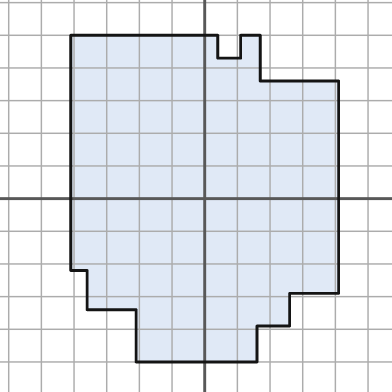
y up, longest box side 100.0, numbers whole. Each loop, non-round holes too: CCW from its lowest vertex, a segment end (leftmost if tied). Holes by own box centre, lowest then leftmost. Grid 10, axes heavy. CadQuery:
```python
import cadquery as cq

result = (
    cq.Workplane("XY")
    .moveTo(-21.0, -50.0)
    .lineTo(16.0, -50.0)
    .lineTo(16.0, -39.0)
    .lineTo(26.0, -39.0)
    .lineTo(26.0, -29.0)
    .lineTo(41.0, -29.0)
    .lineTo(41.0, 36.0)
    .lineTo(17.0, 36.0)
    .lineTo(17.0, 50.0)
    .lineTo(11.0, 50.0)
    .lineTo(11.0, 43.0)
    .lineTo(4.0, 43.0)
    .lineTo(4.0, 50.0)
    .lineTo(-41.0, 50.0)
    .lineTo(-41.0, -22.0)
    .lineTo(-36.0, -22.0)
    .lineTo(-36.0, -34.0)
    .lineTo(-21.0, -34.0)
    .close()
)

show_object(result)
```